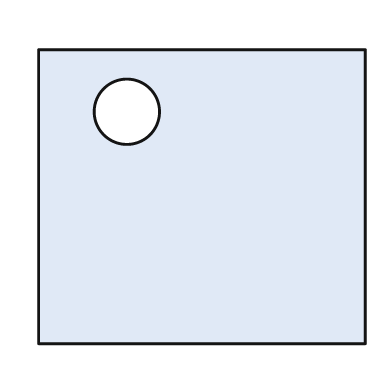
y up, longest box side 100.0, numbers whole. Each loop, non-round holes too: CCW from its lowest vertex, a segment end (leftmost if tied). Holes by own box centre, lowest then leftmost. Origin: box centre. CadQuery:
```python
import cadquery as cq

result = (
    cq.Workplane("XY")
    .moveTo(-50.0, -45.0)
    .lineTo(50.0, -45.0)
    .lineTo(50.0, 45.0)
    .lineTo(-50.0, 45.0)
    .close()
    .moveTo(-23.0, 26.0)
    .circle(10.0)
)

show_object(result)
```